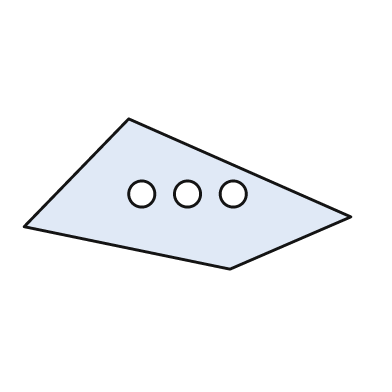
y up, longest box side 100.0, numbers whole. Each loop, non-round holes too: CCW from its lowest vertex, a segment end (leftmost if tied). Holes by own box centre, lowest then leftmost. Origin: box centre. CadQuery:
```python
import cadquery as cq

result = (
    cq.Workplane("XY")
    .moveTo(13.0, -23.0)
    .lineTo(50.0, -7.0)
    .lineTo(-18.0, 23.0)
    .lineTo(-50.0, -10.0)
    .close()
    .moveTo(-14.0, 0.0)
    .circle(4.0)
    .moveTo(0.0, 0.0)
    .circle(4.0)
    .moveTo(14.0, 0.0)
    .circle(4.0)
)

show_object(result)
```